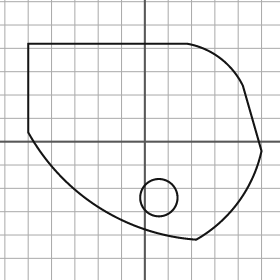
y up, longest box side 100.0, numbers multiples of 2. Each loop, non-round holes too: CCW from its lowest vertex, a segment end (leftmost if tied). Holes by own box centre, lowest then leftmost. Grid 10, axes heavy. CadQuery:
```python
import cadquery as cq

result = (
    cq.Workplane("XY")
    .moveTo(22.0, -42.0)
    .threePointArc((40.0, -26.0), (50.0, -4.0))
    .lineTo(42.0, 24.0)
    .threePointArc((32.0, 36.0), (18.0, 42.0))
    .lineTo(-50.0, 42.0)
    .lineTo(-50.0, 4.0)
    .threePointArc((-20.0, -28.0), (22.0, -42.0))
    .close()
    .moveTo(6.0, -24.0)
    .circle(8.0)
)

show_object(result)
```